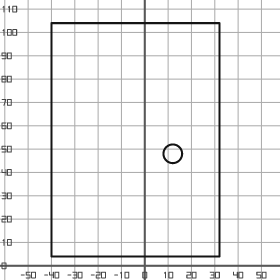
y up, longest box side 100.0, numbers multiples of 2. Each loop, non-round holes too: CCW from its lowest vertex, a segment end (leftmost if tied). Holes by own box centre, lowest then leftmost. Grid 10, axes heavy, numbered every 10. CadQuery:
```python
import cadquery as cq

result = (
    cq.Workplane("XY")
    .moveTo(-40.0, 4.0)
    .lineTo(32.0, 4.0)
    .lineTo(32.0, 104.0)
    .lineTo(-40.0, 104.0)
    .close()
    .moveTo(12.0, 48.0)
    .circle(4.0)
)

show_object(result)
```